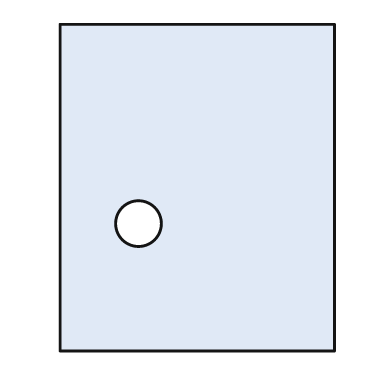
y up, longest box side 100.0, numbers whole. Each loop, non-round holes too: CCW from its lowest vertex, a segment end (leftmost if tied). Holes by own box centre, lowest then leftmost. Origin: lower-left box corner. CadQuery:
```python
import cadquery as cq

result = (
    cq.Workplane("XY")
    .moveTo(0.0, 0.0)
    .lineTo(84.0, 0.0)
    .lineTo(84.0, 100.0)
    .lineTo(0.0, 100.0)
    .close()
    .moveTo(24.0, 39.0)
    .circle(7.0)
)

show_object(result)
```